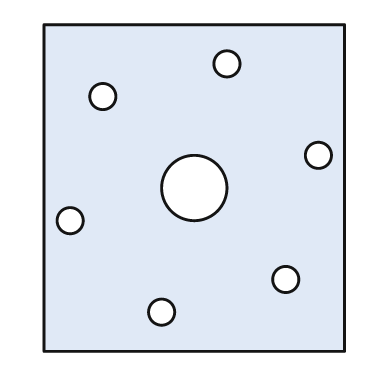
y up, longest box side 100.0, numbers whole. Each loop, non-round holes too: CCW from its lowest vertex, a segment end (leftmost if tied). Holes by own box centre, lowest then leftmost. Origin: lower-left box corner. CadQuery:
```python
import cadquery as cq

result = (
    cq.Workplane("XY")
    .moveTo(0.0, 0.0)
    .lineTo(92.0, 0.0)
    .lineTo(92.0, 100.0)
    .lineTo(0.0, 100.0)
    .close()
    .moveTo(36.0, 12.0)
    .circle(4.0)
    .moveTo(74.0, 22.0)
    .circle(4.0)
    .moveTo(8.0, 40.0)
    .circle(4.0)
    .moveTo(46.0, 50.0)
    .circle(10.0)
    .moveTo(84.0, 60.0)
    .circle(4.0)
    .moveTo(18.0, 78.0)
    .circle(4.0)
    .moveTo(56.0, 88.0)
    .circle(4.0)
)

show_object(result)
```